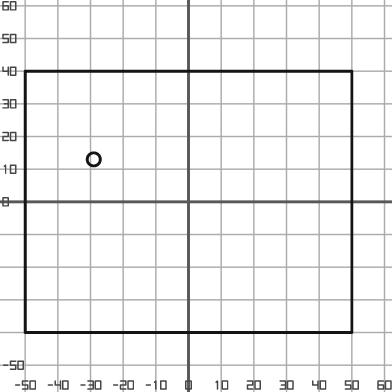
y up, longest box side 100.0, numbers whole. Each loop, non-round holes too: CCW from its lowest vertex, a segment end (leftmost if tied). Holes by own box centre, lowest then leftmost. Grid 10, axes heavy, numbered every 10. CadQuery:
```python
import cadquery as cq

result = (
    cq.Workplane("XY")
    .moveTo(-50.0, -40.0)
    .lineTo(50.0, -40.0)
    .lineTo(50.0, 40.0)
    .lineTo(-50.0, 40.0)
    .close()
    .moveTo(-29.0, 13.0)
    .circle(2.0)
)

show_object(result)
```